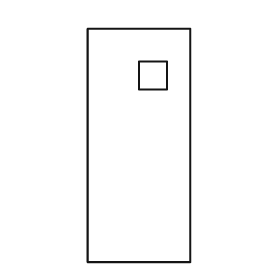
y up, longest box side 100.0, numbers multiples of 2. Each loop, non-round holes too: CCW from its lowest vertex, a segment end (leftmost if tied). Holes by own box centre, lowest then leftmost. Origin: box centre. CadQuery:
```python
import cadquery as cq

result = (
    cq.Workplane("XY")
    .moveTo(-22.0, -50.0)
    .lineTo(22.0, -50.0)
    .lineTo(22.0, 50.0)
    .lineTo(-22.0, 50.0)
    .close()
    .moveTo(0.0, 24.0)
    .lineTo(12.0, 24.0)
    .lineTo(12.0, 36.0)
    .lineTo(0.0, 36.0)
    .close()
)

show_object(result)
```